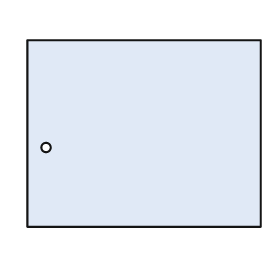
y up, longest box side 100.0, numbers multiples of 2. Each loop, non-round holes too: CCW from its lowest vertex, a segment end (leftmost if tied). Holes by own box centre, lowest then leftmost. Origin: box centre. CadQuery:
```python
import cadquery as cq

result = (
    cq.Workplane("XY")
    .moveTo(-50.0, -40.0)
    .lineTo(50.0, -40.0)
    .lineTo(50.0, 40.0)
    .lineTo(-50.0, 40.0)
    .close()
    .moveTo(-42.0, -6.0)
    .circle(2.0)
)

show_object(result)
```